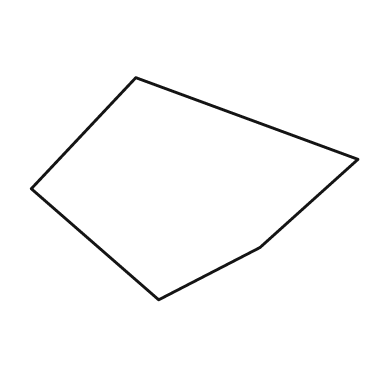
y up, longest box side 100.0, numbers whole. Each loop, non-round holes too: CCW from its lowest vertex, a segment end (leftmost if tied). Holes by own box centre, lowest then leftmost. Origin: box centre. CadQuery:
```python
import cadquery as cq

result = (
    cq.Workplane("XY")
    .moveTo(-11.0, -34.0)
    .lineTo(20.0, -18.0)
    .lineTo(50.0, 9.0)
    .lineTo(-18.0, 34.0)
    .lineTo(-50.0, 0.0)
    .close()
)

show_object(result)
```